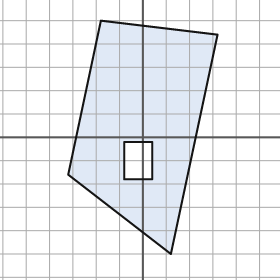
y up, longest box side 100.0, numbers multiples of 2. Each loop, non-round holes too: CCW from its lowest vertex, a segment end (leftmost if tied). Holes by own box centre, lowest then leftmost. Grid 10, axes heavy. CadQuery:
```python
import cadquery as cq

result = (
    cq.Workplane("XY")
    .moveTo(12.0, -50.0)
    .lineTo(32.0, 44.0)
    .lineTo(-18.0, 50.0)
    .lineTo(-32.0, -16.0)
    .close()
    .moveTo(-8.0, -18.0)
    .lineTo(4.0, -18.0)
    .lineTo(4.0, -2.0)
    .lineTo(-8.0, -2.0)
    .close()
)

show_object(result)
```